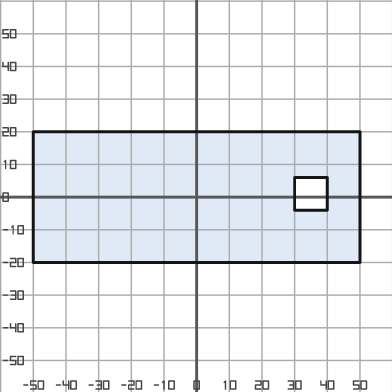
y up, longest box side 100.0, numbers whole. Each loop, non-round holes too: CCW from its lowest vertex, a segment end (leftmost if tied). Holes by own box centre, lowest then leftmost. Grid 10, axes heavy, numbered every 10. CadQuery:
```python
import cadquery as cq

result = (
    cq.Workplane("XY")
    .moveTo(-50.0, -20.0)
    .lineTo(50.0, -20.0)
    .lineTo(50.0, 20.0)
    .lineTo(-50.0, 20.0)
    .close()
    .moveTo(30.0, -4.0)
    .lineTo(40.0, -4.0)
    .lineTo(40.0, 6.0)
    .lineTo(30.0, 6.0)
    .close()
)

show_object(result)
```